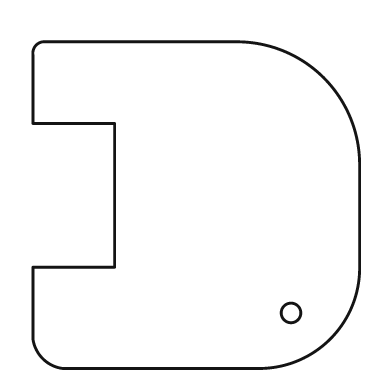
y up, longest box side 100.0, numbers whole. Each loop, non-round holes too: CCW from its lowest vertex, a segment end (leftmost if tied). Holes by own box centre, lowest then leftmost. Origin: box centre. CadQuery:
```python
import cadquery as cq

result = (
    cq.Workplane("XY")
    .moveTo(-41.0, -50.0)
    .lineTo(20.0, -50.0)
    .threePointArc((41.0, -41.0), (50.0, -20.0))
    .lineTo(50.0, 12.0)
    .threePointArc((39.0, 39.0), (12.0, 50.0))
    .lineTo(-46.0, 50.0)
    .threePointArc((-49.0, 49.0), (-50.0, 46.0))
    .lineTo(-50.0, 25.0)
    .lineTo(-25.0, 25.0)
    .lineTo(-25.0, -19.0)
    .lineTo(-50.0, -19.0)
    .lineTo(-50.0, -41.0)
    .threePointArc((-47.0, -47.0), (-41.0, -50.0))
    .close()
    .moveTo(29.0, -33.0)
    .circle(3.0)
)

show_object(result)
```